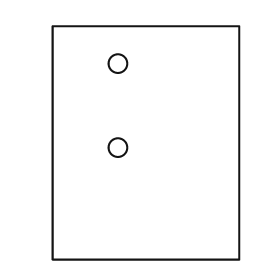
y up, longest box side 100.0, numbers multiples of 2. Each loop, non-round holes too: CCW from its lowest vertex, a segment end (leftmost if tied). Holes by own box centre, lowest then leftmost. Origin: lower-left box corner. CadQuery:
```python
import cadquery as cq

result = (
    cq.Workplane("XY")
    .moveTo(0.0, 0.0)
    .lineTo(80.0, 0.0)
    .lineTo(80.0, 100.0)
    .lineTo(0.0, 100.0)
    .close()
    .moveTo(28.0, 48.0)
    .circle(4.0)
    .moveTo(28.0, 84.0)
    .circle(4.0)
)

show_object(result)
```